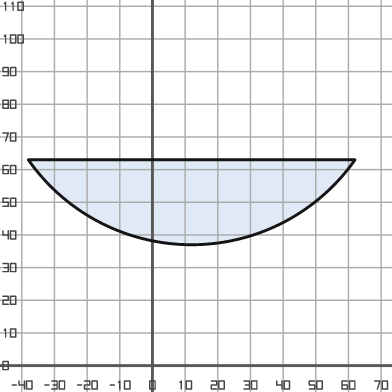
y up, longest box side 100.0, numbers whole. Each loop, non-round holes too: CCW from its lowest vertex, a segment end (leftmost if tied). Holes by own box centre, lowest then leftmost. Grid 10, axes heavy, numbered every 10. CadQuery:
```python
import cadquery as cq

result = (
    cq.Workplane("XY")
    .moveTo(-38.0, 63.0)
    .threePointArc((12.0, 37.0), (62.0, 63.0))
    .close()
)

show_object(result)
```